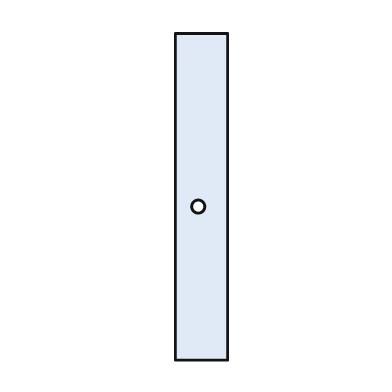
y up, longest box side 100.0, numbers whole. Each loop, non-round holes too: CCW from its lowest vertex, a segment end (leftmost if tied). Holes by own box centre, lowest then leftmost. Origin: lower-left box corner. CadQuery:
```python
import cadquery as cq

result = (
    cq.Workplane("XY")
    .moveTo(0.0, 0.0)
    .lineTo(16.0, 0.0)
    .lineTo(16.0, 100.0)
    .lineTo(0.0, 100.0)
    .close()
    .moveTo(7.0, 47.0)
    .circle(2.0)
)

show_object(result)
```